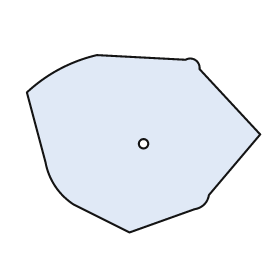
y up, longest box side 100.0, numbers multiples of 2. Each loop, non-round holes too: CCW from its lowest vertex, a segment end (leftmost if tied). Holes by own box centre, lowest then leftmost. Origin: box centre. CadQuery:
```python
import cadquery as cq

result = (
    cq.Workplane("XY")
    .moveTo(-6.0, -38.0)
    .lineTo(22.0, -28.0)
    .threePointArc((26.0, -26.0), (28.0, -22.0))
    .lineTo(50.0, 4.0)
    .lineTo(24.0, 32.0)
    .threePointArc((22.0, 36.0), (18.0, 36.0))
    .lineTo(-20.0, 38.0)
    .threePointArc((-36.0, 32.0), (-50.0, 22.0))
    .lineTo(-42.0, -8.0)
    .threePointArc((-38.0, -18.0), (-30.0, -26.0))
    .close()
    .moveTo(0.0, 0.0)
    .circle(2.0)
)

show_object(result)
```